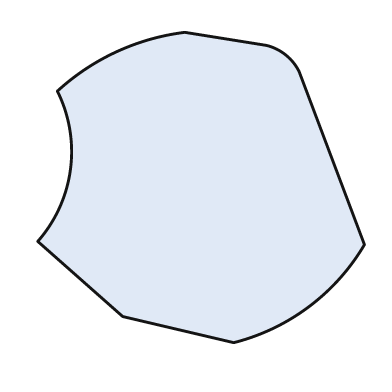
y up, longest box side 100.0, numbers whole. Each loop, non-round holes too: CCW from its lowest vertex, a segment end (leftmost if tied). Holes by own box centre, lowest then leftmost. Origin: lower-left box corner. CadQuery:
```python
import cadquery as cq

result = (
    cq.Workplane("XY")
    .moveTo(60.0, 0.0)
    .threePointArc((83.0, 11.0), (100.0, 30.0))
    .lineTo(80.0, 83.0)
    .threePointArc((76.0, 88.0), (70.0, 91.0))
    .lineTo(45.0, 95.0)
    .threePointArc((24.0, 89.0), (6.0, 77.0))
    .threePointArc((10.0, 53.0), (0.0, 31.0))
    .lineTo(26.0, 8.0)
    .close()
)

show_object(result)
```